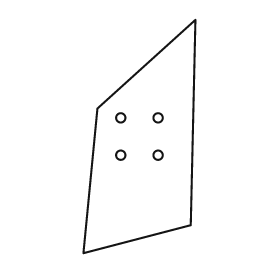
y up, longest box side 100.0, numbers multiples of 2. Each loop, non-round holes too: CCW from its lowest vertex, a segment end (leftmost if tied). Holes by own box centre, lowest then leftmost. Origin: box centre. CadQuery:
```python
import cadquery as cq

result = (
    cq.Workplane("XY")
    .moveTo(-24.0, -50.0)
    .lineTo(22.0, -38.0)
    .lineTo(24.0, 50.0)
    .lineTo(-18.0, 12.0)
    .close()
    .moveTo(-8.0, -8.0)
    .circle(2.0)
    .moveTo(8.0, -8.0)
    .circle(2.0)
    .moveTo(-8.0, 8.0)
    .circle(2.0)
    .moveTo(8.0, 8.0)
    .circle(2.0)
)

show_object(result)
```